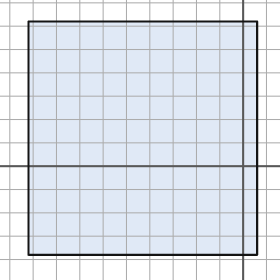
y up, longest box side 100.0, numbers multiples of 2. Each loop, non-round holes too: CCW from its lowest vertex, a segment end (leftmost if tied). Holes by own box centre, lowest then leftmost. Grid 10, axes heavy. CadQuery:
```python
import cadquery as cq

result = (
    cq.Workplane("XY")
    .moveTo(-92.0, -38.0)
    .lineTo(6.0, -38.0)
    .lineTo(6.0, 62.0)
    .lineTo(-92.0, 62.0)
    .close()
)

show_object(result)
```